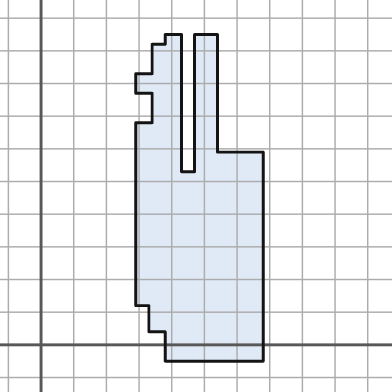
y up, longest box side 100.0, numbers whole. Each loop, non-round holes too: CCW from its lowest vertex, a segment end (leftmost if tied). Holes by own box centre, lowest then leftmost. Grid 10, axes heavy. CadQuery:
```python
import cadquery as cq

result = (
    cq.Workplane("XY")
    .moveTo(38.0, -5.0)
    .lineTo(68.0, -5.0)
    .lineTo(68.0, 59.0)
    .lineTo(54.0, 59.0)
    .lineTo(54.0, 95.0)
    .lineTo(47.0, 95.0)
    .lineTo(47.0, 53.0)
    .lineTo(43.0, 53.0)
    .lineTo(43.0, 95.0)
    .lineTo(38.0, 95.0)
    .lineTo(38.0, 92.0)
    .lineTo(34.0, 92.0)
    .lineTo(34.0, 83.0)
    .lineTo(29.0, 83.0)
    .lineTo(29.0, 77.0)
    .lineTo(34.0, 77.0)
    .lineTo(34.0, 68.0)
    .lineTo(29.0, 68.0)
    .lineTo(29.0, 12.0)
    .lineTo(33.0, 12.0)
    .lineTo(33.0, 4.0)
    .lineTo(38.0, 4.0)
    .close()
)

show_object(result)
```